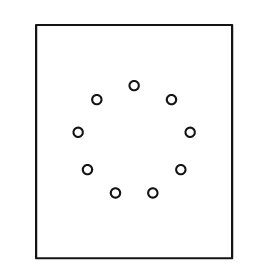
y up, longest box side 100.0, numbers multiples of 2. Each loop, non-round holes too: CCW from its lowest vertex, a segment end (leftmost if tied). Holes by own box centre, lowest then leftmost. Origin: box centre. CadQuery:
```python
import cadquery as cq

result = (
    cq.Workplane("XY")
    .moveTo(-42.0, -50.0)
    .lineTo(42.0, -50.0)
    .lineTo(42.0, 50.0)
    .lineTo(-42.0, 50.0)
    .close()
    .moveTo(-8.0, -22.0)
    .circle(2.0)
    .moveTo(8.0, -22.0)
    .circle(2.0)
    .moveTo(-20.0, -12.0)
    .circle(2.0)
    .moveTo(20.0, -12.0)
    .circle(2.0)
    .moveTo(-24.0, 4.0)
    .circle(2.0)
    .moveTo(24.0, 4.0)
    .circle(2.0)
    .moveTo(-16.0, 18.0)
    .circle(2.0)
    .moveTo(16.0, 18.0)
    .circle(2.0)
    .moveTo(0.0, 24.0)
    .circle(2.0)
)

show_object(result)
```